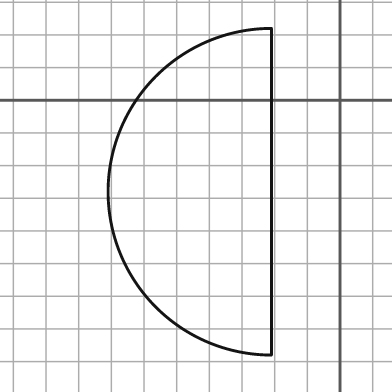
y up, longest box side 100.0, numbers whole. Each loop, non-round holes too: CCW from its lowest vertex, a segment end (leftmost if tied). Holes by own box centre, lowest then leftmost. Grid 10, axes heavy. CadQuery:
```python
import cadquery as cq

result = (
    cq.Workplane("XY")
    .moveTo(-21.0, -78.0)
    .lineTo(-21.0, 22.0)
    .threePointArc((-71.0, -28.0), (-21.0, -78.0))
    .close()
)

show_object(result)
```